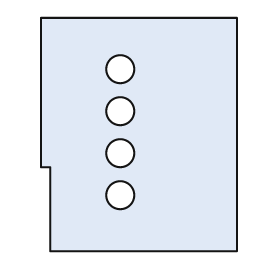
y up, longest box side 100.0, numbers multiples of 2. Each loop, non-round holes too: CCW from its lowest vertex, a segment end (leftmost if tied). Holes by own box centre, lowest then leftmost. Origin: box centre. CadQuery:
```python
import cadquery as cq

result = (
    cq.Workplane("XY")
    .moveTo(-38.0, -50.0)
    .lineTo(42.0, -50.0)
    .lineTo(42.0, 50.0)
    .lineTo(-42.0, 50.0)
    .lineTo(-42.0, -14.0)
    .lineTo(-38.0, -14.0)
    .close()
    .moveTo(-8.0, -26.0)
    .circle(6.0)
    .moveTo(-8.0, -8.0)
    .circle(6.0)
    .moveTo(-8.0, 10.0)
    .circle(6.0)
    .moveTo(-8.0, 28.0)
    .circle(6.0)
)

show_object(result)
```